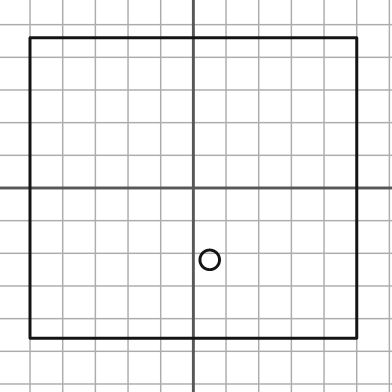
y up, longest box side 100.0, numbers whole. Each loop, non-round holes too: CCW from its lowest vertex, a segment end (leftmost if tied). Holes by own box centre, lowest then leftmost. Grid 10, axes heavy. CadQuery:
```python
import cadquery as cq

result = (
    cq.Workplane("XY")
    .moveTo(-50.0, -46.0)
    .lineTo(50.0, -46.0)
    .lineTo(50.0, 46.0)
    .lineTo(-50.0, 46.0)
    .close()
    .moveTo(5.0, -22.0)
    .circle(3.0)
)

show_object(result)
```